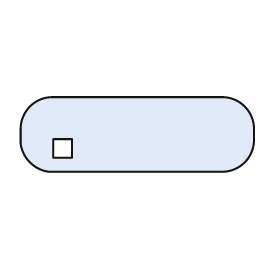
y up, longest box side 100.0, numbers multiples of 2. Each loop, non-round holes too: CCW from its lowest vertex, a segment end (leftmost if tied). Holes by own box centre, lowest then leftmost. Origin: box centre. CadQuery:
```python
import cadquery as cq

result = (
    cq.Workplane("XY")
    .moveTo(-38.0, -16.0)
    .lineTo(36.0, -16.0)
    .threePointArc((46.0, -12.0), (50.0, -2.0))
    .lineTo(50.0, 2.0)
    .threePointArc((46.0, 12.0), (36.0, 16.0))
    .lineTo(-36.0, 16.0)
    .threePointArc((-46.0, 12.0), (-50.0, 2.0))
    .lineTo(-50.0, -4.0)
    .threePointArc((-46.0, -12.0), (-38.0, -16.0))
    .close()
    .moveTo(-36.0, -10.0)
    .lineTo(-28.0, -10.0)
    .lineTo(-28.0, -2.0)
    .lineTo(-36.0, -2.0)
    .close()
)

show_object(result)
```